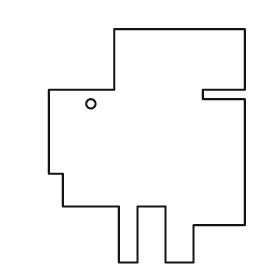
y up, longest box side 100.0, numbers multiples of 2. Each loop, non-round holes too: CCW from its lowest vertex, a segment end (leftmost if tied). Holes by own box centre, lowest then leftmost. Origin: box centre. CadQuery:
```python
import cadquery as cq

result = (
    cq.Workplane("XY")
    .moveTo(-12.0, -50.0)
    .lineTo(-4.0, -50.0)
    .lineTo(-4.0, -26.0)
    .lineTo(8.0, -26.0)
    .lineTo(8.0, -50.0)
    .lineTo(20.0, -50.0)
    .lineTo(20.0, -34.0)
    .lineTo(42.0, -34.0)
    .lineTo(42.0, 20.0)
    .lineTo(24.0, 20.0)
    .lineTo(24.0, 24.0)
    .lineTo(42.0, 24.0)
    .lineTo(42.0, 50.0)
    .lineTo(-14.0, 50.0)
    .lineTo(-14.0, 24.0)
    .lineTo(-42.0, 24.0)
    .lineTo(-42.0, -12.0)
    .lineTo(-36.0, -12.0)
    .lineTo(-36.0, -26.0)
    .lineTo(-12.0, -26.0)
    .close()
    .moveTo(-24.0, 18.0)
    .circle(2.0)
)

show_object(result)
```